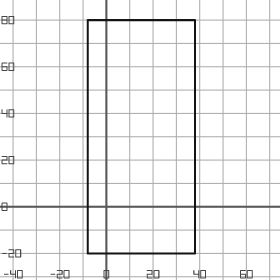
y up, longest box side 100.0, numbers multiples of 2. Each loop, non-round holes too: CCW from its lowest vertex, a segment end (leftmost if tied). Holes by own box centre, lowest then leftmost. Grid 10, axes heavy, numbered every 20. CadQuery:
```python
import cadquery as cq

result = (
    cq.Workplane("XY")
    .moveTo(-8.0, -20.0)
    .lineTo(38.0, -20.0)
    .lineTo(38.0, 80.0)
    .lineTo(-8.0, 80.0)
    .close()
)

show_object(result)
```